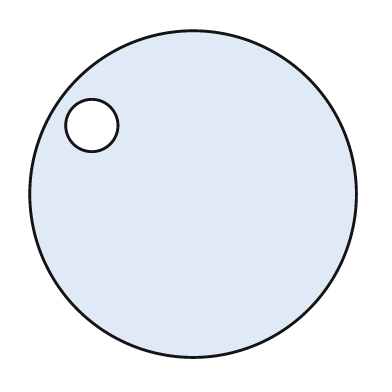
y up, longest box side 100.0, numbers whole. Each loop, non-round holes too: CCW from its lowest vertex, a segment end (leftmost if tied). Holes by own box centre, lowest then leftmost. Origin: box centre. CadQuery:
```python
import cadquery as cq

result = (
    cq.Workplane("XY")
    .moveTo(0.0, 0.0)
    .circle(50.0)
    .moveTo(-31.0, 21.0)
    .circle(8.0)
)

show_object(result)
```